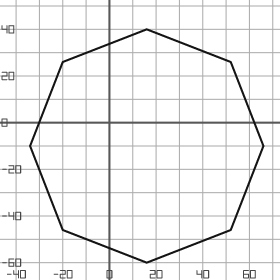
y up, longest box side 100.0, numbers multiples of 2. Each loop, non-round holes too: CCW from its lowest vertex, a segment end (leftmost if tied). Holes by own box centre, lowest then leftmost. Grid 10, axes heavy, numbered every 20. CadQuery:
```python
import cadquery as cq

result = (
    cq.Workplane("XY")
    .moveTo(16.0, -60.0)
    .lineTo(52.0, -46.0)
    .lineTo(66.0, -10.0)
    .lineTo(52.0, 26.0)
    .lineTo(16.0, 40.0)
    .lineTo(-20.0, 26.0)
    .lineTo(-34.0, -10.0)
    .lineTo(-20.0, -46.0)
    .close()
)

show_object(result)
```